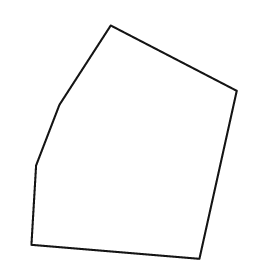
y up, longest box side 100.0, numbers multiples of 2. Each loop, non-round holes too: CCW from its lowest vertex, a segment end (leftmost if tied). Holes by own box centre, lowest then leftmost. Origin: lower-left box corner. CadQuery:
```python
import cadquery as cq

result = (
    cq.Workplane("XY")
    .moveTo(72.0, 0.0)
    .lineTo(88.0, 72.0)
    .lineTo(34.0, 100.0)
    .lineTo(12.0, 66.0)
    .lineTo(2.0, 40.0)
    .lineTo(0.0, 6.0)
    .close()
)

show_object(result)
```